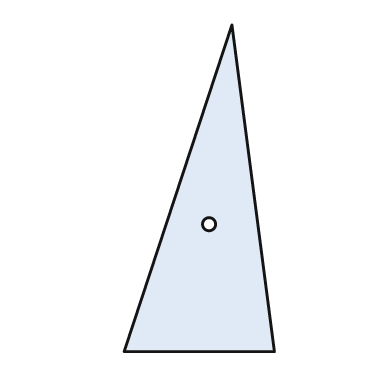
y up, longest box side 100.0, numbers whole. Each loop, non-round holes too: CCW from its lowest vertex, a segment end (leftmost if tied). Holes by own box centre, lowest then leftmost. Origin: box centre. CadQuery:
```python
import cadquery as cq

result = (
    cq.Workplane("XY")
    .moveTo(-23.0, -50.0)
    .lineTo(23.0, -50.0)
    .lineTo(10.0, 50.0)
    .close()
    .moveTo(3.0, -11.0)
    .circle(2.0)
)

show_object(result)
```